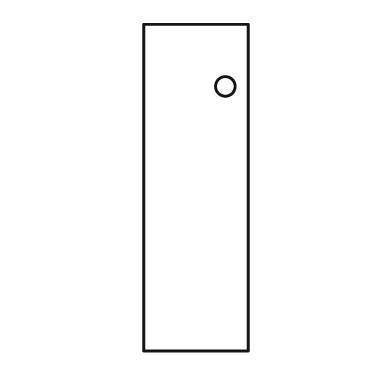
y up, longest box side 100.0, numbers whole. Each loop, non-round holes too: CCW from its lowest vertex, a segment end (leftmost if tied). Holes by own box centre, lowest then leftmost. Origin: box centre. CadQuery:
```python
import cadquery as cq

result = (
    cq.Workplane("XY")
    .moveTo(-16.0, -50.0)
    .lineTo(16.0, -50.0)
    .lineTo(16.0, 50.0)
    .lineTo(-16.0, 50.0)
    .close()
    .moveTo(9.0, 31.0)
    .circle(3.0)
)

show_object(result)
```